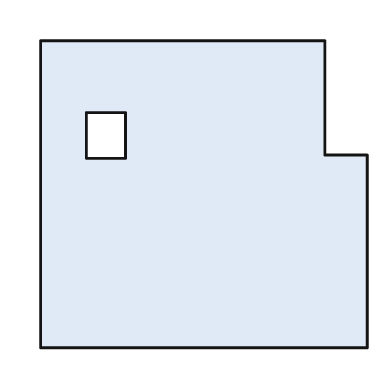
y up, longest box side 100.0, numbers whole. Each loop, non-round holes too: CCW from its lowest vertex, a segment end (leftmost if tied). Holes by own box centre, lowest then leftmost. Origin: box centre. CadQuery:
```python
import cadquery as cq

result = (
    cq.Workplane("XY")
    .moveTo(-50.0, -47.0)
    .lineTo(50.0, -47.0)
    .lineTo(50.0, 12.0)
    .lineTo(37.0, 12.0)
    .lineTo(37.0, 47.0)
    .lineTo(-50.0, 47.0)
    .close()
    .moveTo(-36.0, 11.0)
    .lineTo(-24.0, 11.0)
    .lineTo(-24.0, 25.0)
    .lineTo(-36.0, 25.0)
    .close()
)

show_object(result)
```